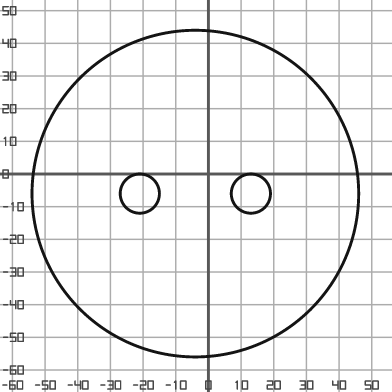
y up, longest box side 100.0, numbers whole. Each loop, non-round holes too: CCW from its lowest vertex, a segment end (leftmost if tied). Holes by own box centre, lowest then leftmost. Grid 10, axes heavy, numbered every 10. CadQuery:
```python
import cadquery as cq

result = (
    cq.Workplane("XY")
    .moveTo(-4.0, -6.0)
    .circle(50.0)
    .moveTo(-21.0, -6.0)
    .circle(6.0)
    .moveTo(13.0, -6.0)
    .circle(6.0)
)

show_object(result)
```